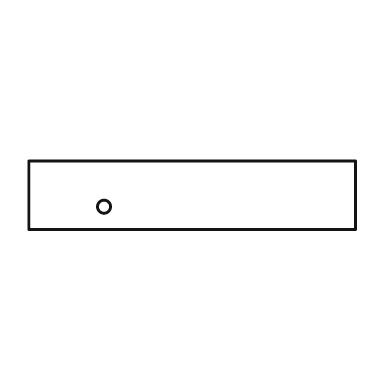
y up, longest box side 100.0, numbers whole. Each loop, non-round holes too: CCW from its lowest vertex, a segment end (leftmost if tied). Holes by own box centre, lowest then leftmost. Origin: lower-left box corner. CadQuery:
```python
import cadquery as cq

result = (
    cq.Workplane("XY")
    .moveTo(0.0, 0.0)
    .lineTo(100.0, 0.0)
    .lineTo(100.0, 21.0)
    .lineTo(0.0, 21.0)
    .close()
    .moveTo(23.0, 7.0)
    .circle(2.0)
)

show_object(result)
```